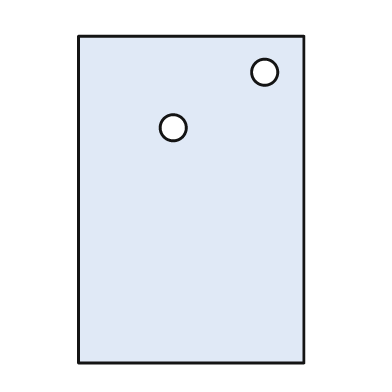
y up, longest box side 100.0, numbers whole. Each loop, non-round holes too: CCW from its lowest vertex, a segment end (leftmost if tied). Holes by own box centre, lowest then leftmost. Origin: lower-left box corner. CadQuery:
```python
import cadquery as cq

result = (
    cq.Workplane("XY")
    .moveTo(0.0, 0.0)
    .lineTo(69.0, 0.0)
    .lineTo(69.0, 100.0)
    .lineTo(0.0, 100.0)
    .close()
    .moveTo(29.0, 72.0)
    .circle(4.0)
    .moveTo(57.0, 89.0)
    .circle(4.0)
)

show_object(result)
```